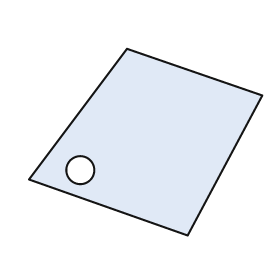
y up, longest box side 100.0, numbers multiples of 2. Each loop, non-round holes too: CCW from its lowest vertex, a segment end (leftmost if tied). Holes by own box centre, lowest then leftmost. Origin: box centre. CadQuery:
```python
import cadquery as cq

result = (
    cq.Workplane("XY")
    .moveTo(18.0, -40.0)
    .lineTo(50.0, 20.0)
    .lineTo(-8.0, 40.0)
    .lineTo(-50.0, -16.0)
    .close()
    .moveTo(-28.0, -12.0)
    .circle(6.0)
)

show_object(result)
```